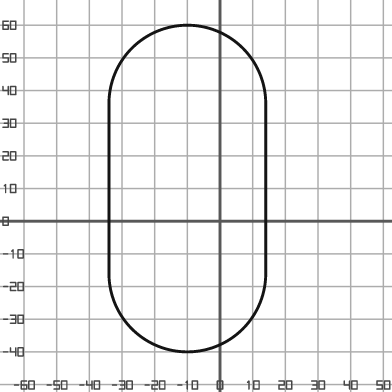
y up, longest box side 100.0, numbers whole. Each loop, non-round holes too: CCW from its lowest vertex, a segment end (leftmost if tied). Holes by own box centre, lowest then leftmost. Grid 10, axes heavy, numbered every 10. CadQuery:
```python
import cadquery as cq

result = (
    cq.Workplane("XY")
    .moveTo(-34.0, -16.0)
    .threePointArc((-10.0, -40.0), (14.0, -16.0))
    .lineTo(14.0, 36.0)
    .threePointArc((-10.0, 60.0), (-34.0, 36.0))
    .close()
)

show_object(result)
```